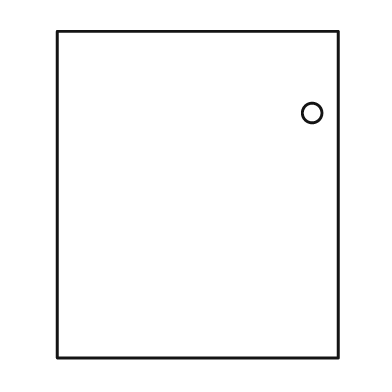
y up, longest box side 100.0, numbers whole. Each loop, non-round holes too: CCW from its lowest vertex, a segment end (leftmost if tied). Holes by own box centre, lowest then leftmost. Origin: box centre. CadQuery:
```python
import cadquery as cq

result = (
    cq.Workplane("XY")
    .moveTo(-43.0, -50.0)
    .lineTo(43.0, -50.0)
    .lineTo(43.0, 50.0)
    .lineTo(-43.0, 50.0)
    .close()
    .moveTo(35.0, 25.0)
    .circle(3.0)
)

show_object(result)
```